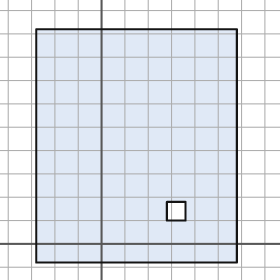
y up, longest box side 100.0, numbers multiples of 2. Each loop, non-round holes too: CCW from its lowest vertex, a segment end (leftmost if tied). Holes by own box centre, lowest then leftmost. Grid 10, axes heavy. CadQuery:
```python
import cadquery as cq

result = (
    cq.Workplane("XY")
    .moveTo(-28.0, -8.0)
    .lineTo(58.0, -8.0)
    .lineTo(58.0, 92.0)
    .lineTo(-28.0, 92.0)
    .close()
    .moveTo(28.0, 10.0)
    .lineTo(36.0, 10.0)
    .lineTo(36.0, 18.0)
    .lineTo(28.0, 18.0)
    .close()
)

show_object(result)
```